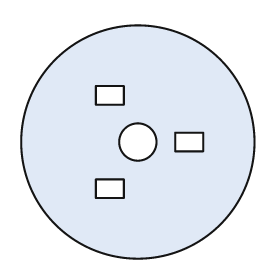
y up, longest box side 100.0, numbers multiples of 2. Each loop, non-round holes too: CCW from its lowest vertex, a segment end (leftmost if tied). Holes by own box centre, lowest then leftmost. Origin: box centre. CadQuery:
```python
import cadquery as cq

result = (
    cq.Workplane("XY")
    .moveTo(0.0, 0.0)
    .circle(50.0)
    .moveTo(-18.0, -24.0)
    .lineTo(-6.0, -24.0)
    .lineTo(-6.0, -16.0)
    .lineTo(-18.0, -16.0)
    .close()
    .moveTo(0.0, 0.0)
    .circle(8.0)
    .moveTo(16.0, -4.0)
    .lineTo(28.0, -4.0)
    .lineTo(28.0, 4.0)
    .lineTo(16.0, 4.0)
    .close()
    .moveTo(-18.0, 16.0)
    .lineTo(-6.0, 16.0)
    .lineTo(-6.0, 24.0)
    .lineTo(-18.0, 24.0)
    .close()
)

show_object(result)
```